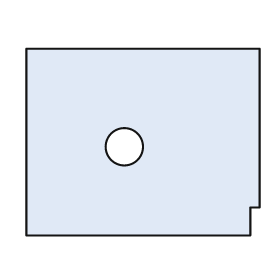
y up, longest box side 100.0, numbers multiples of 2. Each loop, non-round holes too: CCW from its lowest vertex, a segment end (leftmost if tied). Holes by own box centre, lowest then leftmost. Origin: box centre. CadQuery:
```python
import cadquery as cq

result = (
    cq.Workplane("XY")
    .moveTo(-50.0, -40.0)
    .lineTo(46.0, -40.0)
    .lineTo(46.0, -28.0)
    .lineTo(50.0, -28.0)
    .lineTo(50.0, 40.0)
    .lineTo(-50.0, 40.0)
    .close()
    .moveTo(-8.0, -2.0)
    .circle(8.0)
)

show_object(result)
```